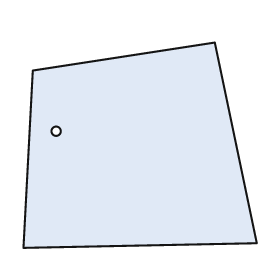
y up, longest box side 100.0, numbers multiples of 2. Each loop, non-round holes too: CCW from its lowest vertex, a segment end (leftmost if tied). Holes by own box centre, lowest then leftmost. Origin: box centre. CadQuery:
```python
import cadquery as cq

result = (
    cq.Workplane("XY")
    .moveTo(-50.0, -44.0)
    .lineTo(50.0, -42.0)
    .lineTo(32.0, 44.0)
    .lineTo(-46.0, 32.0)
    .close()
    .moveTo(-36.0, 6.0)
    .circle(2.0)
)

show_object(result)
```